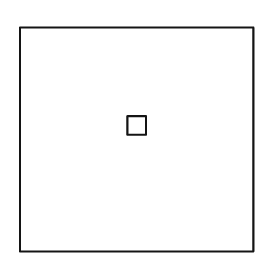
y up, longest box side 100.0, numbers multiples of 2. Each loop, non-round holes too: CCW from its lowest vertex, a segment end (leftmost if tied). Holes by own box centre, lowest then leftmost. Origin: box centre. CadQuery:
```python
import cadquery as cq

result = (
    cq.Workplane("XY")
    .moveTo(-50.0, -48.0)
    .lineTo(50.0, -48.0)
    .lineTo(50.0, 48.0)
    .lineTo(-50.0, 48.0)
    .close()
    .moveTo(-4.0, 2.0)
    .lineTo(4.0, 2.0)
    .lineTo(4.0, 10.0)
    .lineTo(-4.0, 10.0)
    .close()
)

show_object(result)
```